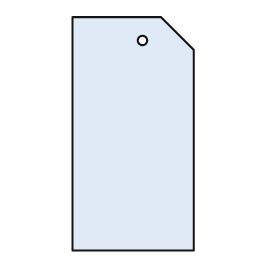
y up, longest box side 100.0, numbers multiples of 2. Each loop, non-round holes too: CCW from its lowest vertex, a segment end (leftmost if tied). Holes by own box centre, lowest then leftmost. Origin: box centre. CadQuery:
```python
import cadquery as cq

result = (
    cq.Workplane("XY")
    .moveTo(-26.0, -50.0)
    .lineTo(26.0, -50.0)
    .lineTo(26.0, 36.0)
    .lineTo(12.0, 50.0)
    .lineTo(-26.0, 50.0)
    .close()
    .moveTo(4.0, 40.0)
    .circle(2.0)
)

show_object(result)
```